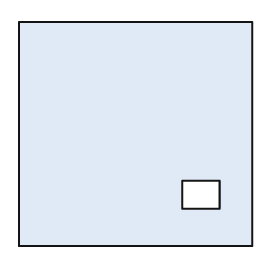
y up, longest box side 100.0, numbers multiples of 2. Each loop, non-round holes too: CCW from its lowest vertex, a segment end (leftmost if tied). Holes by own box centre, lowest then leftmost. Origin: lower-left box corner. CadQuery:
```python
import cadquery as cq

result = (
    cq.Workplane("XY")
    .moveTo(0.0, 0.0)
    .lineTo(100.0, 0.0)
    .lineTo(100.0, 96.0)
    .lineTo(0.0, 96.0)
    .close()
    .moveTo(70.0, 16.0)
    .lineTo(86.0, 16.0)
    .lineTo(86.0, 28.0)
    .lineTo(70.0, 28.0)
    .close()
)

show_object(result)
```